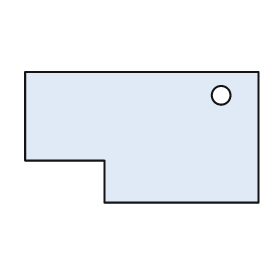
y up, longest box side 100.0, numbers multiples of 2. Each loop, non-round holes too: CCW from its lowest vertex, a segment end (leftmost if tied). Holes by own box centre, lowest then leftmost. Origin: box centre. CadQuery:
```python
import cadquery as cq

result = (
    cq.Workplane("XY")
    .moveTo(-16.0, -28.0)
    .lineTo(50.0, -28.0)
    .lineTo(50.0, 28.0)
    .lineTo(-50.0, 28.0)
    .lineTo(-50.0, -10.0)
    .lineTo(-16.0, -10.0)
    .close()
    .moveTo(34.0, 18.0)
    .circle(4.0)
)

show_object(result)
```